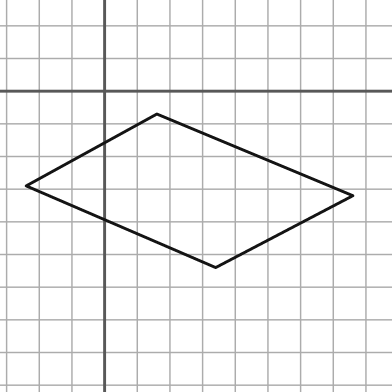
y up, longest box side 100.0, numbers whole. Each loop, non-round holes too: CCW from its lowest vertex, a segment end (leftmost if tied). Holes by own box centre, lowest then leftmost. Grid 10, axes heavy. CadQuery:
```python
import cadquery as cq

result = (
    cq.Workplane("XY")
    .moveTo(34.0, -54.0)
    .lineTo(76.0, -32.0)
    .lineTo(16.0, -7.0)
    .lineTo(-24.0, -29.0)
    .close()
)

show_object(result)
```